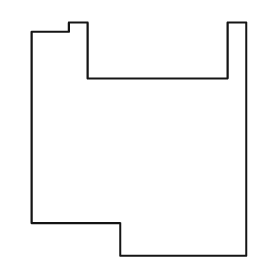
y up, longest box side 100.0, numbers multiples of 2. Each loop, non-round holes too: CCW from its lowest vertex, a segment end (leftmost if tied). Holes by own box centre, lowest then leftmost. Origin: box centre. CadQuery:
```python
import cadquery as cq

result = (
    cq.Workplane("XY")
    .moveTo(-8.0, -50.0)
    .lineTo(46.0, -50.0)
    .lineTo(46.0, 50.0)
    .lineTo(38.0, 50.0)
    .lineTo(38.0, 26.0)
    .lineTo(-22.0, 26.0)
    .lineTo(-22.0, 50.0)
    .lineTo(-30.0, 50.0)
    .lineTo(-30.0, 46.0)
    .lineTo(-46.0, 46.0)
    .lineTo(-46.0, -36.0)
    .lineTo(-8.0, -36.0)
    .close()
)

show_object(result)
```